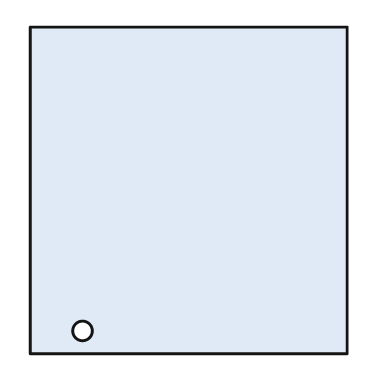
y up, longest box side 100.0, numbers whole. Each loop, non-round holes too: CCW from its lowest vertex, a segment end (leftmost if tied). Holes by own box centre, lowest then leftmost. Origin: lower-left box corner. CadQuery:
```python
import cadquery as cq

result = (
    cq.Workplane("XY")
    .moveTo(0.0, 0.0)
    .lineTo(97.0, 0.0)
    .lineTo(97.0, 100.0)
    .lineTo(0.0, 100.0)
    .close()
    .moveTo(16.0, 7.0)
    .circle(3.0)
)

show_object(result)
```